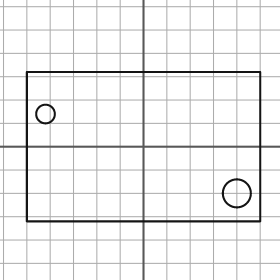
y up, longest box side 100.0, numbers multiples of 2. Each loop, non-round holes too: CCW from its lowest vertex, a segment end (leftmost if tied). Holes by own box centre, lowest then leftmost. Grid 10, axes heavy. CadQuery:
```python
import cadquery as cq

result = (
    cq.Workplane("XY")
    .moveTo(-50.0, -32.0)
    .lineTo(50.0, -32.0)
    .lineTo(50.0, 32.0)
    .lineTo(-50.0, 32.0)
    .close()
    .moveTo(40.0, -20.0)
    .circle(6.0)
    .moveTo(-42.0, 14.0)
    .circle(4.0)
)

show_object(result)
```